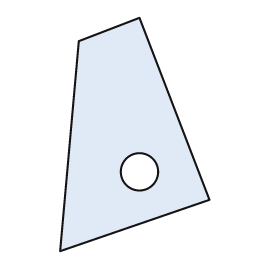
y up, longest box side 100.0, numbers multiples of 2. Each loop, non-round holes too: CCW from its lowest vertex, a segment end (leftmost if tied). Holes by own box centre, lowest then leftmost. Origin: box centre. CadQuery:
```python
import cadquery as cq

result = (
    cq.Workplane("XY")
    .moveTo(-32.0, -50.0)
    .lineTo(32.0, -28.0)
    .lineTo(2.0, 50.0)
    .lineTo(-24.0, 40.0)
    .close()
    .moveTo(2.0, -16.0)
    .circle(8.0)
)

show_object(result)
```